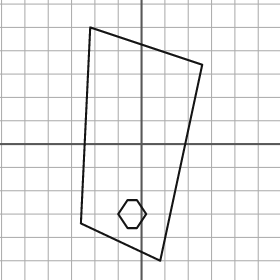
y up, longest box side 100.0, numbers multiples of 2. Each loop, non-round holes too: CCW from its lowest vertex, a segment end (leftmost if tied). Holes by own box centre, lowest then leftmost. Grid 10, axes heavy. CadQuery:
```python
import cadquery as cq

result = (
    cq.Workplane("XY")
    .moveTo(8.0, -50.0)
    .lineTo(26.0, 34.0)
    .lineTo(-22.0, 50.0)
    .lineTo(-26.0, -34.0)
    .close()
    .moveTo(-6.0, -36.0)
    .lineTo(-2.0, -36.0)
    .lineTo(2.0, -30.0)
    .lineTo(-2.0, -24.0)
    .lineTo(-6.0, -24.0)
    .lineTo(-10.0, -30.0)
    .close()
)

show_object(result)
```